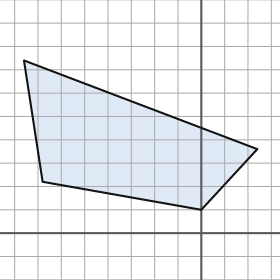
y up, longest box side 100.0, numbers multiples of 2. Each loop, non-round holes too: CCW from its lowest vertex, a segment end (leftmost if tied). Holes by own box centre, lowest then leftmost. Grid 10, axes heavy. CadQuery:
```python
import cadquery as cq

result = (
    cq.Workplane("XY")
    .moveTo(0.0, 10.0)
    .lineTo(24.0, 36.0)
    .lineTo(-76.0, 74.0)
    .lineTo(-68.0, 22.0)
    .close()
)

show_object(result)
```